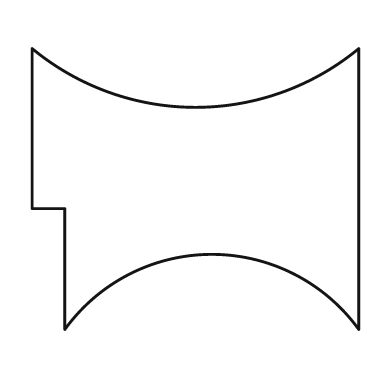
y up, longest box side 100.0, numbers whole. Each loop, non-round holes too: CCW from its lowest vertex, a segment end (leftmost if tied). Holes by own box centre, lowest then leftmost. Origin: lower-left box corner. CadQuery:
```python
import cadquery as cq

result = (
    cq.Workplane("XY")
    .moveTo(10.0, 0.0)
    .threePointArc((55.0, 23.0), (100.0, 0.0))
    .lineTo(100.0, 86.0)
    .threePointArc((50.0, 68.0), (0.0, 86.0))
    .lineTo(0.0, 37.0)
    .lineTo(10.0, 37.0)
    .close()
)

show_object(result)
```